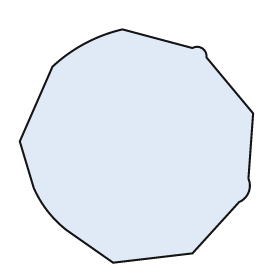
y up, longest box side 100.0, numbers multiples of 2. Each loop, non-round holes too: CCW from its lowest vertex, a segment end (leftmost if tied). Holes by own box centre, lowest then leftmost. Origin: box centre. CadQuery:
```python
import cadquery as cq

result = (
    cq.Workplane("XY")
    .moveTo(-10.0, -50.0)
    .lineTo(24.0, -46.0)
    .lineTo(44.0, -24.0)
    .threePointArc((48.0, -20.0), (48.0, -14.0))
    .lineTo(50.0, 14.0)
    .lineTo(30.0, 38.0)
    .threePointArc((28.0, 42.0), (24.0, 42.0))
    .lineTo(-6.0, 50.0)
    .threePointArc((-22.0, 44.0), (-36.0, 34.0))
    .lineTo(-50.0, 2.0)
    .lineTo(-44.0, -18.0)
    .threePointArc((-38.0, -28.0), (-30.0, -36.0))
    .close()
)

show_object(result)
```